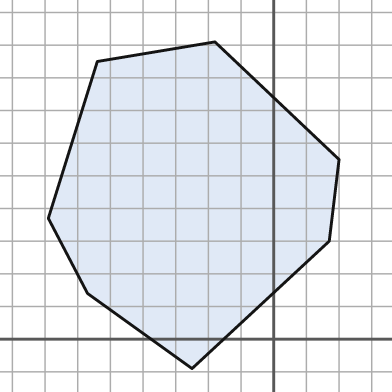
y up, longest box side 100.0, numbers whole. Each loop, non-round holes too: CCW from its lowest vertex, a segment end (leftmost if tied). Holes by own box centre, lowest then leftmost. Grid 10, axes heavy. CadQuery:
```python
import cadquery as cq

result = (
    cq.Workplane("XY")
    .moveTo(-25.0, -9.0)
    .lineTo(17.0, 30.0)
    .lineTo(20.0, 55.0)
    .lineTo(-18.0, 91.0)
    .lineTo(-54.0, 85.0)
    .lineTo(-69.0, 37.0)
    .lineTo(-57.0, 14.0)
    .close()
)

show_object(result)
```